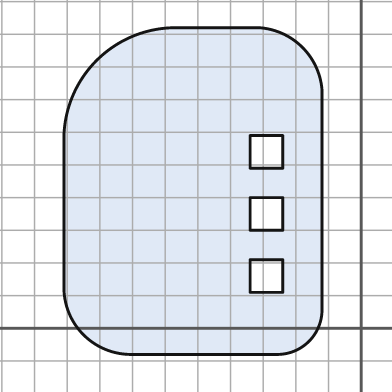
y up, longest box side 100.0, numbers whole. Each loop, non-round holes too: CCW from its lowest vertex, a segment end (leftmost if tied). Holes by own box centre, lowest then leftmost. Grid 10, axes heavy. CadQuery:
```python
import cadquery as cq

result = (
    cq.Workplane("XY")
    .moveTo(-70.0, -8.0)
    .lineTo(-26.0, -8.0)
    .threePointArc((-16.0, -4.0), (-12.0, 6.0))
    .lineTo(-12.0, 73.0)
    .threePointArc((-18.0, 86.0), (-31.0, 92.0))
    .lineTo(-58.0, 92.0)
    .threePointArc((-81.0, 82.0), (-91.0, 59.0))
    .lineTo(-91.0, 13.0)
    .threePointArc((-85.0, -2.0), (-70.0, -8.0))
    .close()
    .moveTo(-34.0, 11.0)
    .lineTo(-24.0, 11.0)
    .lineTo(-24.0, 21.0)
    .lineTo(-34.0, 21.0)
    .close()
    .moveTo(-34.0, 30.0)
    .lineTo(-24.0, 30.0)
    .lineTo(-24.0, 40.0)
    .lineTo(-34.0, 40.0)
    .close()
    .moveTo(-34.0, 49.0)
    .lineTo(-24.0, 49.0)
    .lineTo(-24.0, 59.0)
    .lineTo(-34.0, 59.0)
    .close()
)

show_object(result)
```